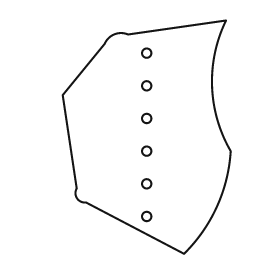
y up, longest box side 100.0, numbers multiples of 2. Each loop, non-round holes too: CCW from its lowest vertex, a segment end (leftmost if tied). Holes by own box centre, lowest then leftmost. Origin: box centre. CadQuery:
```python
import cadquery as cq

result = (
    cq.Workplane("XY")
    .moveTo(16.0, -50.0)
    .threePointArc((30.0, -30.0), (36.0, -6.0))
    .threePointArc((28.0, 22.0), (34.0, 50.0))
    .lineTo(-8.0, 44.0)
    .threePointArc((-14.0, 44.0), (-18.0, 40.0))
    .lineTo(-36.0, 18.0)
    .lineTo(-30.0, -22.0)
    .threePointArc((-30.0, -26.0), (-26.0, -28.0))
    .close()
    .moveTo(0.0, -34.0)
    .circle(2.0)
    .moveTo(0.0, -20.0)
    .circle(2.0)
    .moveTo(0.0, -6.0)
    .circle(2.0)
    .moveTo(0.0, 8.0)
    .circle(2.0)
    .moveTo(0.0, 22.0)
    .circle(2.0)
    .moveTo(0.0, 36.0)
    .circle(2.0)
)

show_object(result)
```